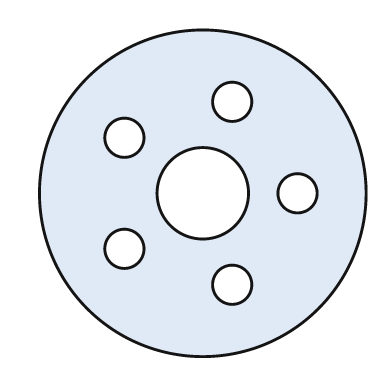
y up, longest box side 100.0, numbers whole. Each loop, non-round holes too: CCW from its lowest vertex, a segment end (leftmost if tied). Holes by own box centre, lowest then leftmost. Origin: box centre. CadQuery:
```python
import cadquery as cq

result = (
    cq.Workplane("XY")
    .moveTo(0.0, 0.0)
    .circle(50.0)
    .moveTo(9.0, -28.0)
    .circle(6.0)
    .moveTo(-24.0, -17.0)
    .circle(6.0)
    .moveTo(0.0, 0.0)
    .circle(14.0)
    .moveTo(29.0, 0.0)
    .circle(6.0)
    .moveTo(-24.0, 17.0)
    .circle(6.0)
    .moveTo(9.0, 28.0)
    .circle(6.0)
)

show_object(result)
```